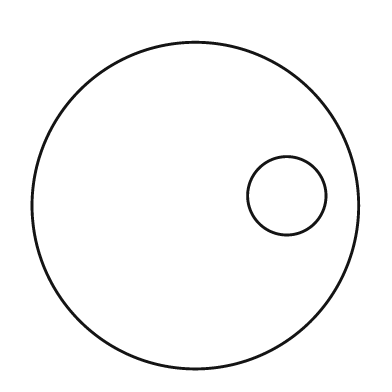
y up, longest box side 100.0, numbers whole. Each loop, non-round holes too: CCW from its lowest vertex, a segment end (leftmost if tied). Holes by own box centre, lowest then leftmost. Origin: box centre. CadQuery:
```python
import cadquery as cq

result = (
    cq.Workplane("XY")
    .moveTo(0.0, 0.0)
    .circle(50.0)
    .moveTo(28.0, 3.0)
    .circle(12.0)
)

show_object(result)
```